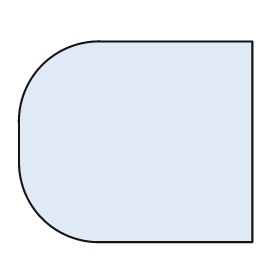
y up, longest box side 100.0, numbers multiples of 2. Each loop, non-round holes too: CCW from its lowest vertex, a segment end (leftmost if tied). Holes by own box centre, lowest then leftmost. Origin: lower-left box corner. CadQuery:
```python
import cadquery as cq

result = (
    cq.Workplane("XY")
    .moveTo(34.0, 0.0)
    .lineTo(100.0, 0.0)
    .lineTo(100.0, 86.0)
    .lineTo(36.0, 86.0)
    .threePointArc((10.0, 76.0), (0.0, 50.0))
    .lineTo(0.0, 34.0)
    .threePointArc((10.0, 10.0), (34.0, 0.0))
    .close()
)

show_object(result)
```